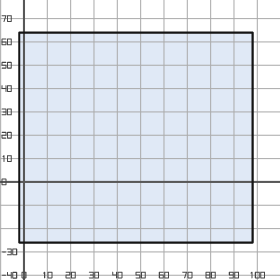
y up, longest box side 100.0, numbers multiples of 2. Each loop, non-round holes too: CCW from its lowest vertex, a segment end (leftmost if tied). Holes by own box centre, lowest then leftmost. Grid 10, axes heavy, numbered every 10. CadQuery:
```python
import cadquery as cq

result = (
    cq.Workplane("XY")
    .moveTo(-2.0, -26.0)
    .lineTo(98.0, -26.0)
    .lineTo(98.0, 64.0)
    .lineTo(-2.0, 64.0)
    .close()
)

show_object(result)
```